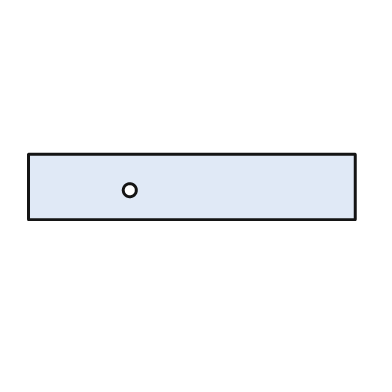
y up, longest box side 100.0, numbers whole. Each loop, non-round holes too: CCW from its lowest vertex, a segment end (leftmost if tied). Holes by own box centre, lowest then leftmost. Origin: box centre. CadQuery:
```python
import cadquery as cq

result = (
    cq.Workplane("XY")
    .moveTo(-50.0, -10.0)
    .lineTo(50.0, -10.0)
    .lineTo(50.0, 10.0)
    .lineTo(-50.0, 10.0)
    .close()
    .moveTo(-19.0, -1.0)
    .circle(2.0)
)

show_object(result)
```